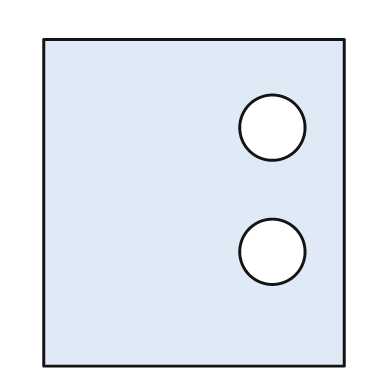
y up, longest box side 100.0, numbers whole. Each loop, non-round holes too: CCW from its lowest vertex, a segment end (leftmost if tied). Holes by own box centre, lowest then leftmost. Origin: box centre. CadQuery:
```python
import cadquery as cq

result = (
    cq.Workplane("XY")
    .moveTo(-46.0, -50.0)
    .lineTo(46.0, -50.0)
    .lineTo(46.0, 50.0)
    .lineTo(-46.0, 50.0)
    .close()
    .moveTo(24.0, -15.0)
    .circle(10.0)
    .moveTo(24.0, 23.0)
    .circle(10.0)
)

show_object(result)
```